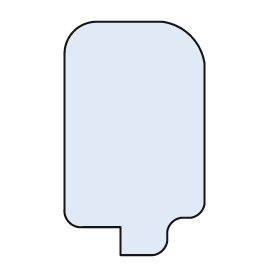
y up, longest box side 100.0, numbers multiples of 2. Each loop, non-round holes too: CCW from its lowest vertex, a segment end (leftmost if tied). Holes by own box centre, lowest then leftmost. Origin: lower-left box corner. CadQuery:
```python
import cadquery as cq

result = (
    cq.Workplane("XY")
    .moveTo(24.0, 0.0)
    .lineTo(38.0, 0.0)
    .threePointArc((42.0, 2.0), (44.0, 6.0))
    .lineTo(44.0, 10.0)
    .threePointArc((46.0, 14.0), (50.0, 16.0))
    .lineTo(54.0, 16.0)
    .threePointArc((58.0, 18.0), (60.0, 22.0))
    .lineTo(60.0, 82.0)
    .threePointArc((54.0, 94.0), (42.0, 100.0))
    .lineTo(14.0, 100.0)
    .threePointArc((4.0, 96.0), (0.0, 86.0))
    .lineTo(0.0, 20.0)
    .threePointArc((2.0, 14.0), (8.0, 12.0))
    .lineTo(24.0, 12.0)
    .close()
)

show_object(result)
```